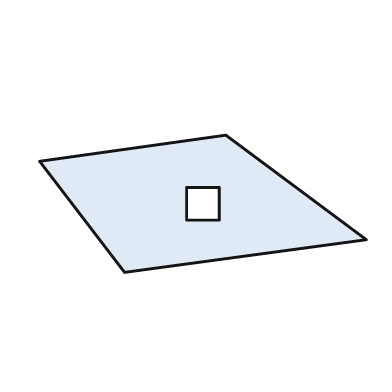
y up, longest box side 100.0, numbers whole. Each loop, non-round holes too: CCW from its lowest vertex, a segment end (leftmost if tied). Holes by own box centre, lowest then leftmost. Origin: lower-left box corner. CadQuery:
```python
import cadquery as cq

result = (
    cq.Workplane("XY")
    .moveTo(26.0, 0.0)
    .lineTo(100.0, 10.0)
    .lineTo(57.0, 42.0)
    .lineTo(0.0, 34.0)
    .close()
    .moveTo(45.0, 16.0)
    .lineTo(55.0, 16.0)
    .lineTo(55.0, 26.0)
    .lineTo(45.0, 26.0)
    .close()
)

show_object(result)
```